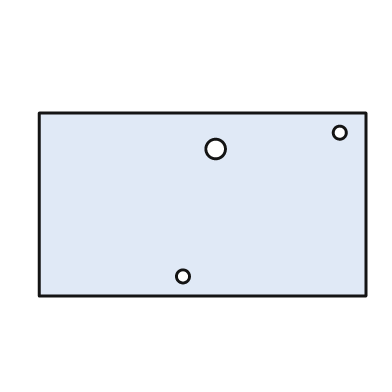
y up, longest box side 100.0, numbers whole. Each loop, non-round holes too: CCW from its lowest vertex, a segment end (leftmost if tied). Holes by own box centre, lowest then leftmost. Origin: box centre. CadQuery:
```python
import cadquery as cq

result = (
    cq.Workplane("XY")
    .moveTo(-50.0, -28.0)
    .lineTo(50.0, -28.0)
    .lineTo(50.0, 28.0)
    .lineTo(-50.0, 28.0)
    .close()
    .moveTo(-6.0, -22.0)
    .circle(2.0)
    .moveTo(4.0, 17.0)
    .circle(3.0)
    .moveTo(42.0, 22.0)
    .circle(2.0)
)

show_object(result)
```